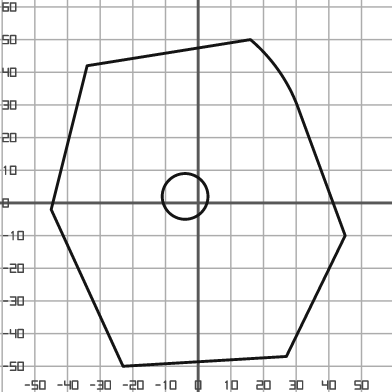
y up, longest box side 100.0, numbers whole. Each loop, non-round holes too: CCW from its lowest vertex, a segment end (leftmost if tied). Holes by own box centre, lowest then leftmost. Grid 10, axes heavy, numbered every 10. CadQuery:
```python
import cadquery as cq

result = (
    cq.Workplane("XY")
    .moveTo(-23.0, -50.0)
    .lineTo(27.0, -47.0)
    .lineTo(45.0, -10.0)
    .lineTo(31.0, 28.0)
    .threePointArc((25.0, 40.0), (16.0, 50.0))
    .lineTo(-34.0, 42.0)
    .lineTo(-45.0, -2.0)
    .close()
    .moveTo(-4.0, 2.0)
    .circle(7.0)
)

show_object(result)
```